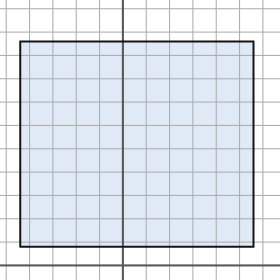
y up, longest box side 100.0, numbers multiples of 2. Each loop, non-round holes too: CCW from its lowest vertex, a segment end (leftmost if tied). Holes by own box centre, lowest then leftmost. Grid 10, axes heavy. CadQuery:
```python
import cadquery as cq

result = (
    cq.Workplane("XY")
    .moveTo(-44.0, 8.0)
    .lineTo(56.0, 8.0)
    .lineTo(56.0, 96.0)
    .lineTo(-44.0, 96.0)
    .close()
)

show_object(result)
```